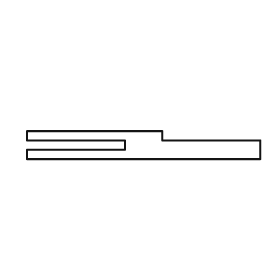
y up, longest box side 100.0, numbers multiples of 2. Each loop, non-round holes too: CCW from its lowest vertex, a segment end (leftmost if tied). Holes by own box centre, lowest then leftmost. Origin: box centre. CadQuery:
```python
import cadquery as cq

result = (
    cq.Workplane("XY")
    .moveTo(-50.0, -6.0)
    .lineTo(50.0, -6.0)
    .lineTo(50.0, 2.0)
    .lineTo(8.0, 2.0)
    .lineTo(8.0, 6.0)
    .lineTo(-50.0, 6.0)
    .lineTo(-50.0, 2.0)
    .lineTo(-8.0, 2.0)
    .lineTo(-8.0, -2.0)
    .lineTo(-50.0, -2.0)
    .close()
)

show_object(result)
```